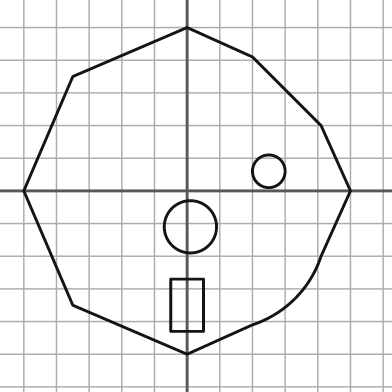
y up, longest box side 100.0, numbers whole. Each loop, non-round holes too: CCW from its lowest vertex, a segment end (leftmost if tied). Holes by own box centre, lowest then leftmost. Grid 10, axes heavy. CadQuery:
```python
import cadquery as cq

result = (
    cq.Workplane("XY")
    .moveTo(0.0, -50.0)
    .lineTo(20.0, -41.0)
    .threePointArc((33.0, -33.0), (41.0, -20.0))
    .lineTo(50.0, 0.0)
    .lineTo(41.0, 20.0)
    .lineTo(20.0, 41.0)
    .lineTo(0.0, 50.0)
    .lineTo(-35.0, 35.0)
    .lineTo(-50.0, 0.0)
    .lineTo(-35.0, -35.0)
    .close()
    .moveTo(-5.0, -43.0)
    .lineTo(5.0, -43.0)
    .lineTo(5.0, -27.0)
    .lineTo(-5.0, -27.0)
    .close()
    .moveTo(1.0, -11.0)
    .circle(8.0)
    .moveTo(25.0, 6.0)
    .circle(5.0)
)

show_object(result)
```